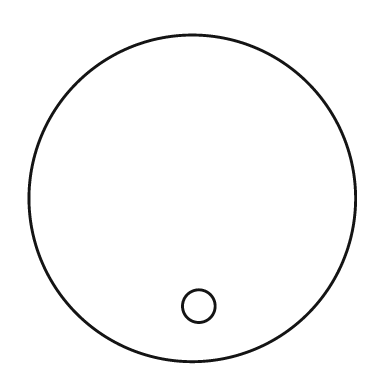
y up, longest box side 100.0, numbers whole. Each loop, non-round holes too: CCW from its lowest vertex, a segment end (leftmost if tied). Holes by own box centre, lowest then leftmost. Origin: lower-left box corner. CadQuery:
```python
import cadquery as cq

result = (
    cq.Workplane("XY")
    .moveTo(50.0, 50.0)
    .circle(50.0)
    .moveTo(52.0, 17.0)
    .circle(5.0)
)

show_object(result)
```